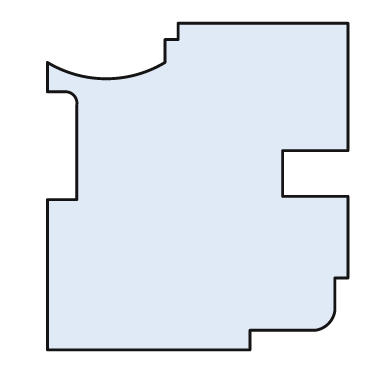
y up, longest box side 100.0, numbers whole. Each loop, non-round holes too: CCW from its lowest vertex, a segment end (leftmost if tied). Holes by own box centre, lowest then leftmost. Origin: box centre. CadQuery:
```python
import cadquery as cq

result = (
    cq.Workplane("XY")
    .moveTo(-46.0, -50.0)
    .lineTo(16.0, -50.0)
    .lineTo(16.0, -44.0)
    .lineTo(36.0, -44.0)
    .threePointArc((40.0, -42.0), (42.0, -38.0))
    .lineTo(42.0, -28.0)
    .lineTo(46.0, -28.0)
    .lineTo(46.0, -3.0)
    .lineTo(26.0, -3.0)
    .lineTo(26.0, 11.0)
    .lineTo(46.0, 11.0)
    .lineTo(46.0, 50.0)
    .lineTo(-6.0, 50.0)
    .lineTo(-6.0, 45.0)
    .lineTo(-10.0, 45.0)
    .lineTo(-10.0, 38.0)
    .threePointArc((-28.0, 33.0), (-46.0, 38.0))
    .lineTo(-46.0, 29.0)
    .lineTo(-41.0, 29.0)
    .threePointArc((-38.0, 28.0), (-37.0, 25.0))
    .lineTo(-37.0, -4.0)
    .lineTo(-46.0, -4.0)
    .close()
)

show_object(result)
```